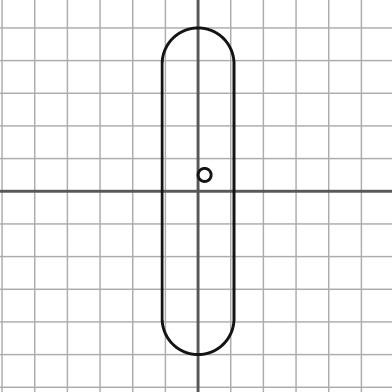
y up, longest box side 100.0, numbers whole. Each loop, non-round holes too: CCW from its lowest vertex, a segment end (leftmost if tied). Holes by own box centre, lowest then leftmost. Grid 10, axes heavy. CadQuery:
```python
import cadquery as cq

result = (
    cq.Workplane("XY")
    .moveTo(-11.0, -39.0)
    .threePointArc((0.0, -50.0), (11.0, -39.0))
    .lineTo(11.0, 39.0)
    .threePointArc((0.0, 50.0), (-11.0, 39.0))
    .close()
    .moveTo(2.0, 5.0)
    .circle(2.0)
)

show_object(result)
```